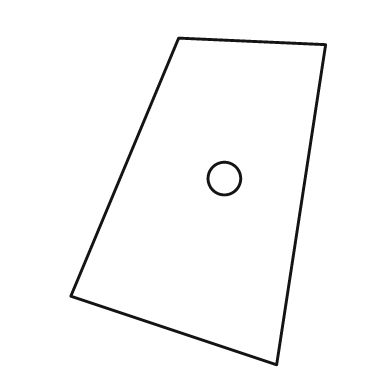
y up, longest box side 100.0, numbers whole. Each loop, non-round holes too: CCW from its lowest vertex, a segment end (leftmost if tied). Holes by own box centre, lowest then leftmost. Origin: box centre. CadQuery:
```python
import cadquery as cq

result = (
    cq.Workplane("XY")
    .moveTo(24.0, -50.0)
    .lineTo(39.0, 48.0)
    .lineTo(-6.0, 50.0)
    .lineTo(-39.0, -29.0)
    .close()
    .moveTo(8.0, 7.0)
    .circle(5.0)
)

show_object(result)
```